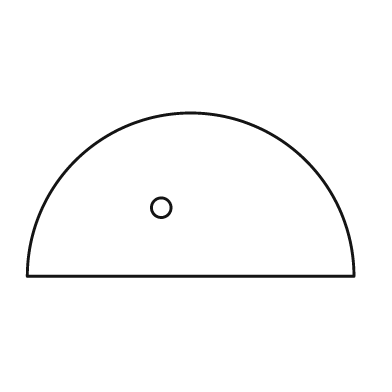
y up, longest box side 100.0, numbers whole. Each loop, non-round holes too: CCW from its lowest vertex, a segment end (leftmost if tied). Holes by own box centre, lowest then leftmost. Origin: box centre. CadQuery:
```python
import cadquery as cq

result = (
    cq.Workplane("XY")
    .moveTo(-50.0, -25.0)
    .lineTo(50.0, -25.0)
    .threePointArc((0.0, 25.0), (-50.0, -25.0))
    .close()
    .moveTo(-9.0, -4.0)
    .circle(3.0)
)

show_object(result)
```